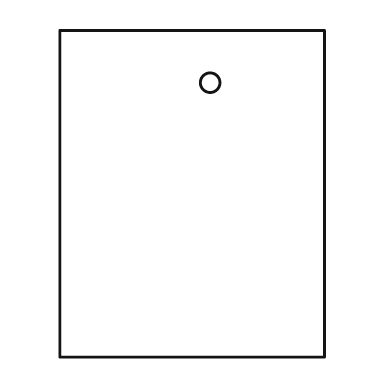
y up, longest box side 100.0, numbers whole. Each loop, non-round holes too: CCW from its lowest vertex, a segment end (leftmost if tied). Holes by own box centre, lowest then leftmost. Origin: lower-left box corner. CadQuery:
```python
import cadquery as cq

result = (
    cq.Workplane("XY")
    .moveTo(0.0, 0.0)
    .lineTo(81.0, 0.0)
    .lineTo(81.0, 100.0)
    .lineTo(0.0, 100.0)
    .close()
    .moveTo(46.0, 84.0)
    .circle(3.0)
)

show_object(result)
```